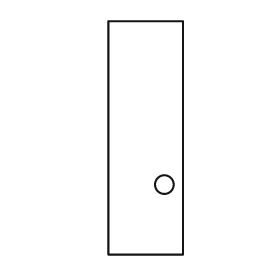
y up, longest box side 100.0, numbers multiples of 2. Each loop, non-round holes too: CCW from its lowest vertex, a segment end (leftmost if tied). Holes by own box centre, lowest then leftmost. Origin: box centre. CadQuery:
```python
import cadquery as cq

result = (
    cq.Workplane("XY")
    .moveTo(-16.0, -50.0)
    .lineTo(16.0, -50.0)
    .lineTo(16.0, 50.0)
    .lineTo(-16.0, 50.0)
    .close()
    .moveTo(8.0, -20.0)
    .circle(4.0)
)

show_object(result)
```